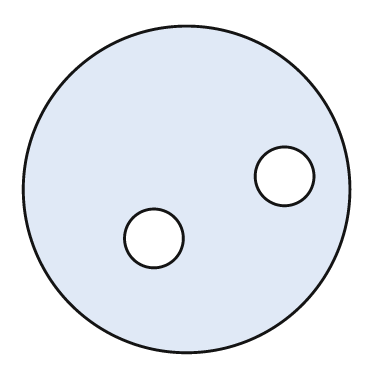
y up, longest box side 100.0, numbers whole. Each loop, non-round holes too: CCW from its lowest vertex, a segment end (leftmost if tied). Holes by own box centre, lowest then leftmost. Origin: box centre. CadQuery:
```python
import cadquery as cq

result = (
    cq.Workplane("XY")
    .moveTo(0.0, 0.0)
    .circle(50.0)
    .moveTo(-10.0, -15.0)
    .circle(9.0)
    .moveTo(30.0, 4.0)
    .circle(9.0)
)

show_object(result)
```